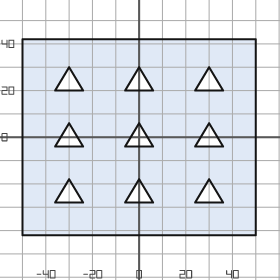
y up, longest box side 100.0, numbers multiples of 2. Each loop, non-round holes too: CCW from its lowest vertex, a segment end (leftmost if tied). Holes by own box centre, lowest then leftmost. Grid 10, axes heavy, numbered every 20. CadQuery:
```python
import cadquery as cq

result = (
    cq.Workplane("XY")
    .moveTo(-50.0, -42.0)
    .lineTo(50.0, -42.0)
    .lineTo(50.0, 42.0)
    .lineTo(-50.0, 42.0)
    .close()
    .moveTo(-36.0, -28.0)
    .lineTo(-24.0, -28.0)
    .lineTo(-30.0, -18.0)
    .close()
    .moveTo(-6.0, -28.0)
    .lineTo(6.0, -28.0)
    .lineTo(0.0, -18.0)
    .close()
    .moveTo(24.0, -28.0)
    .lineTo(36.0, -28.0)
    .lineTo(30.0, -18.0)
    .close()
    .moveTo(-36.0, -4.0)
    .lineTo(-24.0, -4.0)
    .lineTo(-30.0, 6.0)
    .close()
    .moveTo(-6.0, -4.0)
    .lineTo(6.0, -4.0)
    .lineTo(0.0, 6.0)
    .close()
    .moveTo(24.0, -4.0)
    .lineTo(36.0, -4.0)
    .lineTo(30.0, 6.0)
    .close()
    .moveTo(-36.0, 20.0)
    .lineTo(-24.0, 20.0)
    .lineTo(-30.0, 30.0)
    .close()
    .moveTo(-6.0, 20.0)
    .lineTo(6.0, 20.0)
    .lineTo(0.0, 30.0)
    .close()
    .moveTo(24.0, 20.0)
    .lineTo(36.0, 20.0)
    .lineTo(30.0, 30.0)
    .close()
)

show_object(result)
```